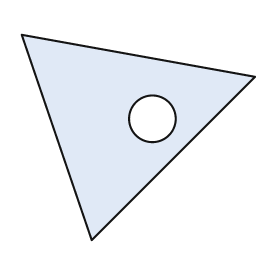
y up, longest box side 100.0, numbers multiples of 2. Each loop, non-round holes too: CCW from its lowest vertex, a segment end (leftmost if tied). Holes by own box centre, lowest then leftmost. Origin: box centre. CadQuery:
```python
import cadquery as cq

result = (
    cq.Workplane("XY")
    .moveTo(-20.0, -44.0)
    .lineTo(50.0, 26.0)
    .lineTo(-50.0, 44.0)
    .close()
    .moveTo(6.0, 8.0)
    .circle(10.0)
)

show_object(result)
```